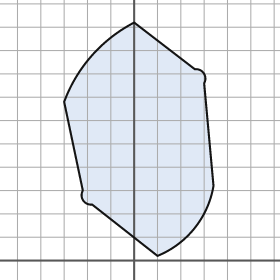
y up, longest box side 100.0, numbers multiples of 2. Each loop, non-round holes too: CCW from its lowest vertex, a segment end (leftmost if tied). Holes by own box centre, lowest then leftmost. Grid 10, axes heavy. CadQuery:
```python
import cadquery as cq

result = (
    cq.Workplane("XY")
    .moveTo(10.0, 2.0)
    .threePointArc((26.0, 14.0), (34.0, 32.0))
    .lineTo(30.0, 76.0)
    .threePointArc((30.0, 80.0), (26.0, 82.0))
    .lineTo(0.0, 102.0)
    .threePointArc((-18.0, 88.0), (-30.0, 68.0))
    .lineTo(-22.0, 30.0)
    .threePointArc((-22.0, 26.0), (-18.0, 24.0))
    .close()
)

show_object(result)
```